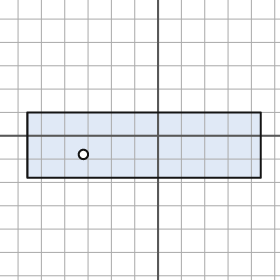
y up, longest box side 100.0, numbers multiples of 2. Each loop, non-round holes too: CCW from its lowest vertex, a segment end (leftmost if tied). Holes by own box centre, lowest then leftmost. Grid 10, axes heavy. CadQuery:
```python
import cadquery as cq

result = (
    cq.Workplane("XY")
    .moveTo(-56.0, -18.0)
    .lineTo(44.0, -18.0)
    .lineTo(44.0, 10.0)
    .lineTo(-56.0, 10.0)
    .close()
    .moveTo(-32.0, -8.0)
    .circle(2.0)
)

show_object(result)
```